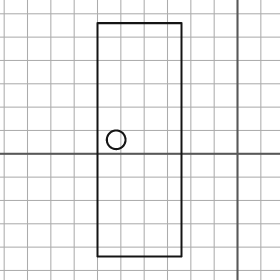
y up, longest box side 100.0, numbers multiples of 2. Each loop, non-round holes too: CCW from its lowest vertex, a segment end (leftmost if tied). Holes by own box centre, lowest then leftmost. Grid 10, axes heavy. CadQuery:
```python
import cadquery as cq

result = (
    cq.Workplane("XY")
    .moveTo(-60.0, -44.0)
    .lineTo(-24.0, -44.0)
    .lineTo(-24.0, 56.0)
    .lineTo(-60.0, 56.0)
    .close()
    .moveTo(-52.0, 6.0)
    .circle(4.0)
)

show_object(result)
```